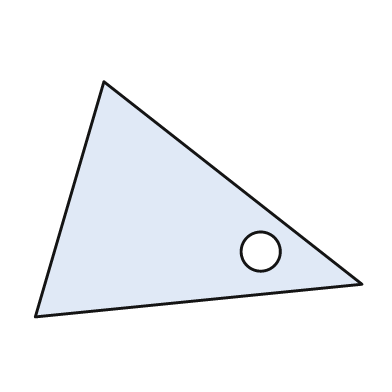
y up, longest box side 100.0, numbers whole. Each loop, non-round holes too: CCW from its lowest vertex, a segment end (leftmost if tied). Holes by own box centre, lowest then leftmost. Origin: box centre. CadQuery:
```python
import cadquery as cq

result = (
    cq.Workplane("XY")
    .moveTo(-50.0, -36.0)
    .lineTo(50.0, -26.0)
    .lineTo(-29.0, 36.0)
    .close()
    .moveTo(19.0, -16.0)
    .circle(6.0)
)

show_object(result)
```